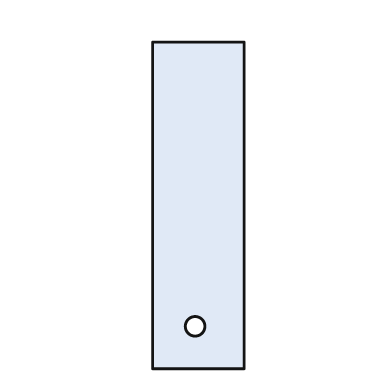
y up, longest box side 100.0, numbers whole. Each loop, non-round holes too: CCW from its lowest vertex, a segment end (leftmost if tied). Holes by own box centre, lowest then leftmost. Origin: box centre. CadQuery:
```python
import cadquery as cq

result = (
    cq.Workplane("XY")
    .moveTo(-14.0, -50.0)
    .lineTo(14.0, -50.0)
    .lineTo(14.0, 50.0)
    .lineTo(-14.0, 50.0)
    .close()
    .moveTo(-1.0, -37.0)
    .circle(3.0)
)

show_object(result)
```